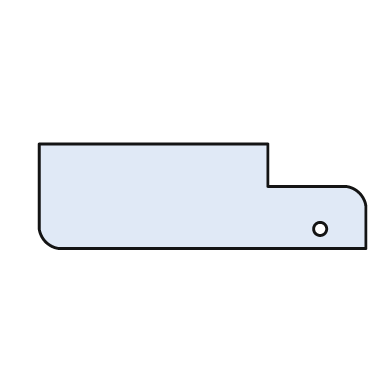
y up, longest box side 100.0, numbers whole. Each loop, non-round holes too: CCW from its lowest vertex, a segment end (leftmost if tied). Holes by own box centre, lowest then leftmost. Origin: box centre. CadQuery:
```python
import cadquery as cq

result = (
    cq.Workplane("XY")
    .moveTo(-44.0, -16.0)
    .lineTo(50.0, -16.0)
    .lineTo(50.0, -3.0)
    .threePointArc((48.0, 1.0), (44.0, 3.0))
    .lineTo(20.0, 3.0)
    .lineTo(20.0, 16.0)
    .lineTo(-50.0, 16.0)
    .lineTo(-50.0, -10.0)
    .threePointArc((-48.0, -14.0), (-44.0, -16.0))
    .close()
    .moveTo(36.0, -10.0)
    .circle(2.0)
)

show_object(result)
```